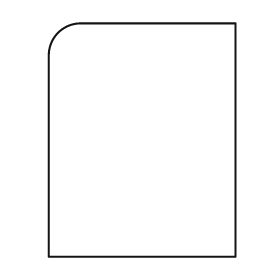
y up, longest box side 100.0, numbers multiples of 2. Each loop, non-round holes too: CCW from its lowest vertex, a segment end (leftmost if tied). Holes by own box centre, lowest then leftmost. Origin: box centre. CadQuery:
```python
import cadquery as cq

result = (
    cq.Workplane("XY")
    .moveTo(-40.0, -50.0)
    .lineTo(40.0, -50.0)
    .lineTo(40.0, 50.0)
    .lineTo(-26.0, 50.0)
    .threePointArc((-36.0, 46.0), (-40.0, 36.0))
    .close()
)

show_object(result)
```